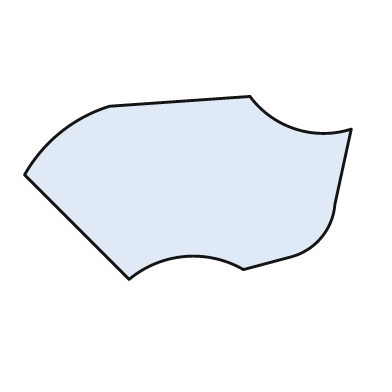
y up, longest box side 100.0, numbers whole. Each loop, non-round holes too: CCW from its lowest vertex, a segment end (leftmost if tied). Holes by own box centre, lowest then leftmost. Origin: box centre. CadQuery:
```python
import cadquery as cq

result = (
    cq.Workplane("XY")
    .moveTo(-18.0, -28.0)
    .threePointArc((-1.0, -21.0), (17.0, -25.0))
    .lineTo(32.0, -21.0)
    .threePointArc((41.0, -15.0), (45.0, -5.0))
    .lineTo(50.0, 18.0)
    .threePointArc((33.0, 18.0), (19.0, 28.0))
    .lineTo(-24.0, 25.0)
    .threePointArc((-39.0, 17.0), (-50.0, 4.0))
    .close()
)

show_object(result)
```